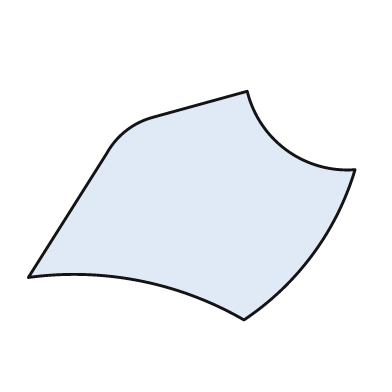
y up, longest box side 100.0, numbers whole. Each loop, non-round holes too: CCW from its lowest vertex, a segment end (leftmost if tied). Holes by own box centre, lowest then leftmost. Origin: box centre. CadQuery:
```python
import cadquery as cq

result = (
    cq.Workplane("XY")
    .moveTo(16.0, -35.0)
    .threePointArc((37.0, -15.0), (50.0, 11.0))
    .threePointArc((29.0, 17.0), (17.0, 35.0))
    .lineTo(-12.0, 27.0)
    .threePointArc((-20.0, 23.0), (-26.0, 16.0))
    .lineTo(-50.0, -22.0)
    .threePointArc((-16.0, -23.0), (16.0, -35.0))
    .close()
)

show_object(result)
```